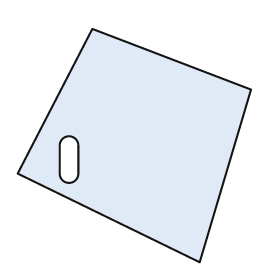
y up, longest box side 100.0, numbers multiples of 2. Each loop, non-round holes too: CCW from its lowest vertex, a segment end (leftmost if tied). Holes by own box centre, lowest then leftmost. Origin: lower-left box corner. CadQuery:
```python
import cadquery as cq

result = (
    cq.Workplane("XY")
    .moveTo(78.0, 0.0)
    .lineTo(100.0, 74.0)
    .lineTo(32.0, 100.0)
    .lineTo(0.0, 38.0)
    .close()
    .moveTo(18.0, 38.0)
    .threePointArc((22.0, 34.0), (26.0, 38.0))
    .lineTo(26.0, 50.0)
    .threePointArc((22.0, 54.0), (18.0, 50.0))
    .close()
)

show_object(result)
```